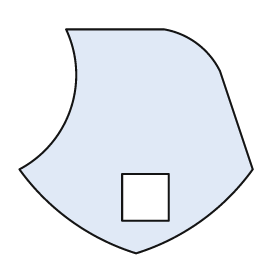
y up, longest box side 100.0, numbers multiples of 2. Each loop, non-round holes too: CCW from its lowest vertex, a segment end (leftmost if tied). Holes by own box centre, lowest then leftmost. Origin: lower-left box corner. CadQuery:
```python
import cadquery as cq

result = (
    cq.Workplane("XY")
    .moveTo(50.0, 0.0)
    .threePointArc((78.0, 14.0), (100.0, 36.0))
    .lineTo(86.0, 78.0)
    .threePointArc((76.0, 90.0), (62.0, 96.0))
    .lineTo(20.0, 96.0)
    .threePointArc((22.0, 62.0), (0.0, 36.0))
    .threePointArc((22.0, 14.0), (50.0, 0.0))
    .close()
    .moveTo(44.0, 14.0)
    .lineTo(64.0, 14.0)
    .lineTo(64.0, 34.0)
    .lineTo(44.0, 34.0)
    .close()
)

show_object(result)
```